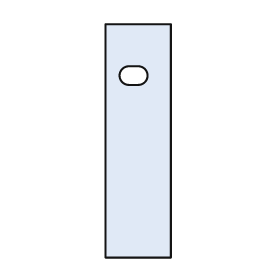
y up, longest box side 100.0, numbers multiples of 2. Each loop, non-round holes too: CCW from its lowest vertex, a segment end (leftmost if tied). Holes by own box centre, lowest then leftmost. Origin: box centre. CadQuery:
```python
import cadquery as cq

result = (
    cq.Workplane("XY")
    .moveTo(-14.0, -50.0)
    .lineTo(14.0, -50.0)
    .lineTo(14.0, 50.0)
    .lineTo(-14.0, 50.0)
    .close()
    .moveTo(-4.0, 24.0)
    .lineTo(0.0, 24.0)
    .threePointArc((4.0, 28.0), (0.0, 32.0))
    .lineTo(-4.0, 32.0)
    .threePointArc((-8.0, 28.0), (-4.0, 24.0))
    .close()
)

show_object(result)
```